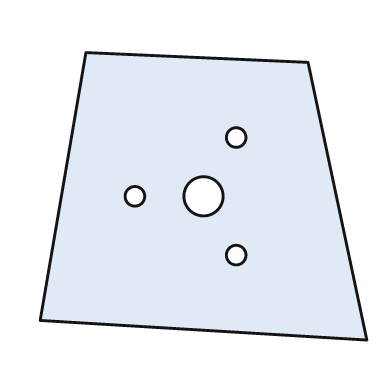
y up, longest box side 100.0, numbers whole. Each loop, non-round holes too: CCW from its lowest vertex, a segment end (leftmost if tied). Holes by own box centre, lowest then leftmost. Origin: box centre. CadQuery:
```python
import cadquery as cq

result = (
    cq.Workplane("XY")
    .moveTo(50.0, -44.0)
    .lineTo(32.0, 41.0)
    .lineTo(-36.0, 44.0)
    .lineTo(-50.0, -38.0)
    .close()
    .moveTo(10.0, -18.0)
    .circle(3.0)
    .moveTo(-21.0, 0.0)
    .circle(3.0)
    .moveTo(0.0, 0.0)
    .circle(6.0)
    .moveTo(10.0, 18.0)
    .circle(3.0)
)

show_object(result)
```